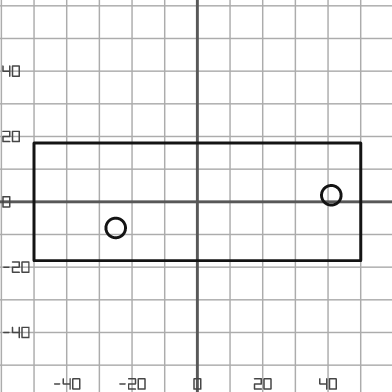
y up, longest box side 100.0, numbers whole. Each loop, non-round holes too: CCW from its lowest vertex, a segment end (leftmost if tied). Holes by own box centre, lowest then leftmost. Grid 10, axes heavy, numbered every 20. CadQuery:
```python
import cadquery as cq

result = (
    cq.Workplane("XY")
    .moveTo(-50.0, -18.0)
    .lineTo(50.0, -18.0)
    .lineTo(50.0, 18.0)
    .lineTo(-50.0, 18.0)
    .close()
    .moveTo(-25.0, -8.0)
    .circle(3.0)
    .moveTo(41.0, 2.0)
    .circle(3.0)
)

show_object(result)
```